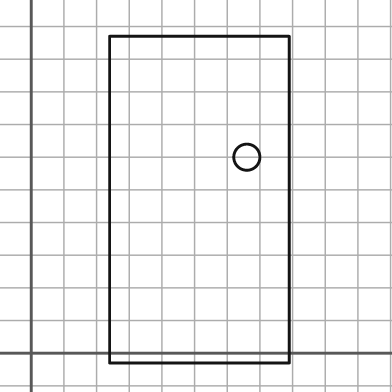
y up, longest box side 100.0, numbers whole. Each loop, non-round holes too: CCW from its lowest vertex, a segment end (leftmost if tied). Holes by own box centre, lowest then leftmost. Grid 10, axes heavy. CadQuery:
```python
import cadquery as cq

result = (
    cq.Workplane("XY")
    .moveTo(24.0, -3.0)
    .lineTo(79.0, -3.0)
    .lineTo(79.0, 97.0)
    .lineTo(24.0, 97.0)
    .close()
    .moveTo(66.0, 60.0)
    .circle(4.0)
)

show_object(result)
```